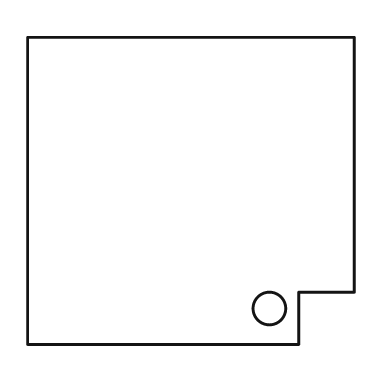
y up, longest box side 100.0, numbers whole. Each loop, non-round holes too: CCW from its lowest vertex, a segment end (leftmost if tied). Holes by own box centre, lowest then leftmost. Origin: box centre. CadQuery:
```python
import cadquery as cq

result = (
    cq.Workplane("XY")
    .moveTo(-50.0, -47.0)
    .lineTo(33.0, -47.0)
    .lineTo(33.0, -31.0)
    .lineTo(50.0, -31.0)
    .lineTo(50.0, 47.0)
    .lineTo(-50.0, 47.0)
    .close()
    .moveTo(24.0, -36.0)
    .circle(5.0)
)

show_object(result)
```